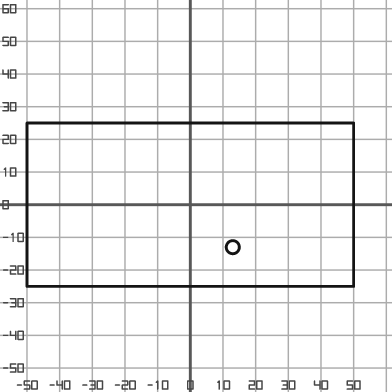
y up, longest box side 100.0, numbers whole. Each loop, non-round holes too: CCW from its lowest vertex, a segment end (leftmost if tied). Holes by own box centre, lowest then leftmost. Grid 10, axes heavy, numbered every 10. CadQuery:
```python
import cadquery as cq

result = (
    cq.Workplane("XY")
    .moveTo(-50.0, -25.0)
    .lineTo(50.0, -25.0)
    .lineTo(50.0, 25.0)
    .lineTo(-50.0, 25.0)
    .close()
    .moveTo(13.0, -13.0)
    .circle(2.0)
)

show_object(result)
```